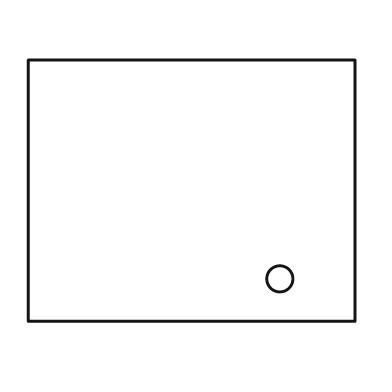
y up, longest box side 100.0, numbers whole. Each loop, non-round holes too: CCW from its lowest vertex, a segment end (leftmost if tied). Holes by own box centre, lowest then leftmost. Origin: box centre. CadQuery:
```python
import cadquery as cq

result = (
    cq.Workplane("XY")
    .moveTo(-50.0, -40.0)
    .lineTo(50.0, -40.0)
    .lineTo(50.0, 40.0)
    .lineTo(-50.0, 40.0)
    .close()
    .moveTo(27.0, -27.0)
    .circle(4.0)
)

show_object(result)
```